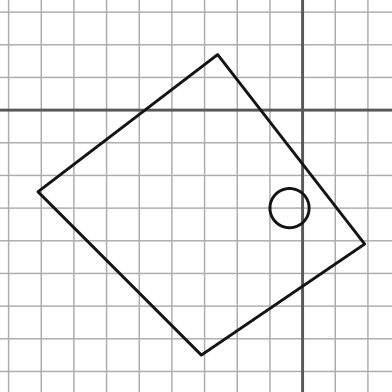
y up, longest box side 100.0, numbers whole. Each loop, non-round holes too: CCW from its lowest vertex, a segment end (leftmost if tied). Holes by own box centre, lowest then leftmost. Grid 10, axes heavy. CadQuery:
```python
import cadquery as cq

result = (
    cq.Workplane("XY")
    .moveTo(-31.0, -75.0)
    .lineTo(19.0, -41.0)
    .lineTo(-26.0, 17.0)
    .lineTo(-81.0, -25.0)
    .close()
    .moveTo(-4.0, -30.0)
    .circle(6.0)
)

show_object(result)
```